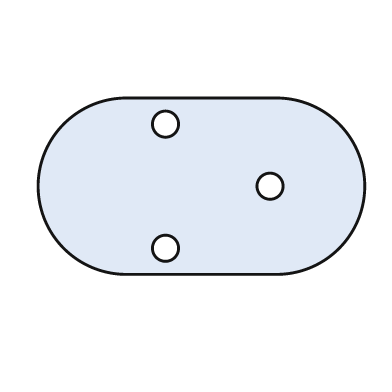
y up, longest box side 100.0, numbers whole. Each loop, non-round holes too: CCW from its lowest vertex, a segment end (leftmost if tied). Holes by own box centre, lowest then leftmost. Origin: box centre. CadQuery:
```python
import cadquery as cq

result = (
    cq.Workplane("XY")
    .moveTo(-23.0, -27.0)
    .lineTo(23.0, -27.0)
    .threePointArc((50.0, 0.0), (23.0, 27.0))
    .lineTo(-23.0, 27.0)
    .threePointArc((-50.0, 0.0), (-23.0, -27.0))
    .close()
    .moveTo(-11.0, -19.0)
    .circle(4.0)
    .moveTo(21.0, 0.0)
    .circle(4.0)
    .moveTo(-11.0, 19.0)
    .circle(4.0)
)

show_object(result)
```